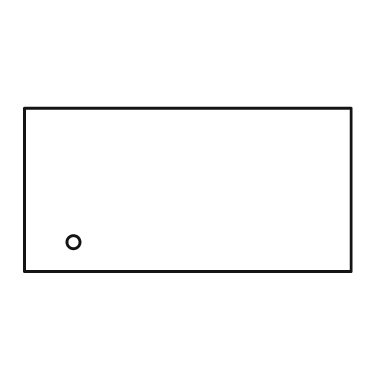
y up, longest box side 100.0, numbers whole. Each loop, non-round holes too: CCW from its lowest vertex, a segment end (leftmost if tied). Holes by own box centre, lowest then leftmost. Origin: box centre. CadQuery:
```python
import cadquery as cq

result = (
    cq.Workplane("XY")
    .moveTo(-50.0, -25.0)
    .lineTo(50.0, -25.0)
    .lineTo(50.0, 25.0)
    .lineTo(-50.0, 25.0)
    .close()
    .moveTo(-35.0, -16.0)
    .circle(2.0)
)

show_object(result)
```